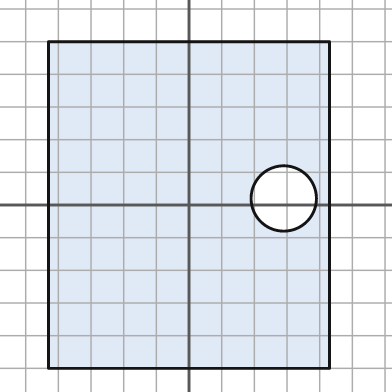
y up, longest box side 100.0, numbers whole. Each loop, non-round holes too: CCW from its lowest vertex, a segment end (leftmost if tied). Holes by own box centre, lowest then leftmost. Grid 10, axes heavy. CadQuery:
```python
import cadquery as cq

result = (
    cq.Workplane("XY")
    .moveTo(-43.0, -50.0)
    .lineTo(43.0, -50.0)
    .lineTo(43.0, 50.0)
    .lineTo(-43.0, 50.0)
    .close()
    .moveTo(29.0, 2.0)
    .circle(10.0)
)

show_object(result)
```